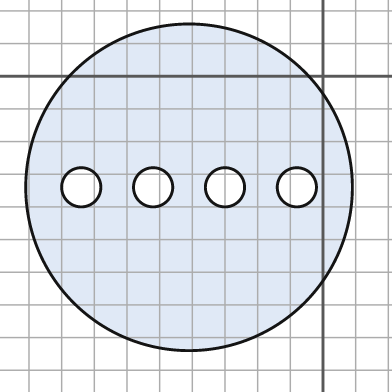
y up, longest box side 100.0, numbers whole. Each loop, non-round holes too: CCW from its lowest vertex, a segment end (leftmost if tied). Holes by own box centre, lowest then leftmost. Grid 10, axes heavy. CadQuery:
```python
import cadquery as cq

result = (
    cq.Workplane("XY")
    .moveTo(-41.0, -34.0)
    .circle(50.0)
    .moveTo(-74.0, -34.0)
    .circle(6.0)
    .moveTo(-52.0, -34.0)
    .circle(6.0)
    .moveTo(-30.0, -34.0)
    .circle(6.0)
    .moveTo(-8.0, -34.0)
    .circle(6.0)
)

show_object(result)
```